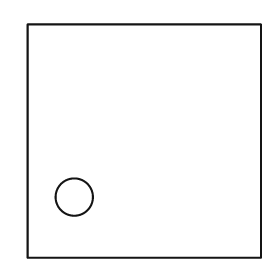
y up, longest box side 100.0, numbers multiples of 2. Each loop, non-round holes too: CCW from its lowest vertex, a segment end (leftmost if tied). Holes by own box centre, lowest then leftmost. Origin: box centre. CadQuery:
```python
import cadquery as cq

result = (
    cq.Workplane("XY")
    .moveTo(-50.0, -50.0)
    .lineTo(50.0, -50.0)
    .lineTo(50.0, 50.0)
    .lineTo(-50.0, 50.0)
    .close()
    .moveTo(-30.0, -24.0)
    .circle(8.0)
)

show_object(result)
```